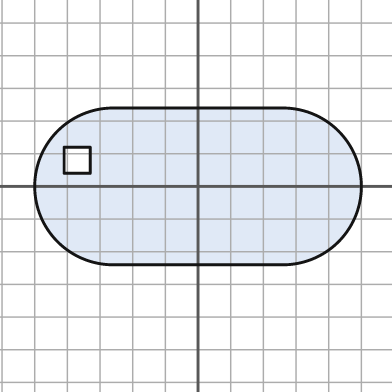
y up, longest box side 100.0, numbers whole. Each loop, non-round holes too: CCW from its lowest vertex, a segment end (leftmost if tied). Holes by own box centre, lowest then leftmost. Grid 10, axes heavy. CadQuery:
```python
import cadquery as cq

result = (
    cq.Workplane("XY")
    .moveTo(-26.0, -24.0)
    .lineTo(26.0, -24.0)
    .threePointArc((50.0, 0.0), (26.0, 24.0))
    .lineTo(-26.0, 24.0)
    .threePointArc((-50.0, 0.0), (-26.0, -24.0))
    .close()
    .moveTo(-41.0, 4.0)
    .lineTo(-33.0, 4.0)
    .lineTo(-33.0, 12.0)
    .lineTo(-41.0, 12.0)
    .close()
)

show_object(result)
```